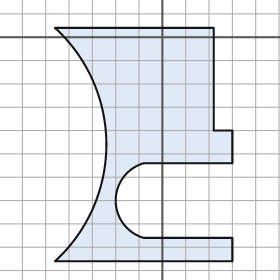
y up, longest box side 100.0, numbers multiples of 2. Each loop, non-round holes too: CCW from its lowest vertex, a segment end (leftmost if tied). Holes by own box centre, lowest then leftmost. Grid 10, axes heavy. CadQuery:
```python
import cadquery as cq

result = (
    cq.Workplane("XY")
    .moveTo(-46.0, -96.0)
    .lineTo(30.0, -96.0)
    .lineTo(30.0, -86.0)
    .lineTo(-8.0, -86.0)
    .threePointArc((-20.0, -70.0), (-8.0, -54.0))
    .lineTo(30.0, -54.0)
    .lineTo(30.0, -40.0)
    .lineTo(22.0, -40.0)
    .lineTo(22.0, 4.0)
    .lineTo(-46.0, 4.0)
    .threePointArc((-24.0, -46.0), (-46.0, -96.0))
    .close()
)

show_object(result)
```